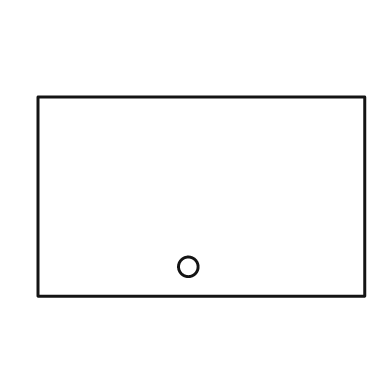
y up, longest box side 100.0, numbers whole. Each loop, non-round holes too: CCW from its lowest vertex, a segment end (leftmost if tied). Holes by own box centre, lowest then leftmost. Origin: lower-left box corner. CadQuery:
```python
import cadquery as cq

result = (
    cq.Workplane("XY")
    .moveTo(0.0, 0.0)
    .lineTo(100.0, 0.0)
    .lineTo(100.0, 61.0)
    .lineTo(0.0, 61.0)
    .close()
    .moveTo(46.0, 9.0)
    .circle(3.0)
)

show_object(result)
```